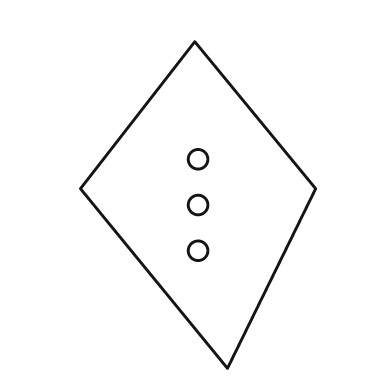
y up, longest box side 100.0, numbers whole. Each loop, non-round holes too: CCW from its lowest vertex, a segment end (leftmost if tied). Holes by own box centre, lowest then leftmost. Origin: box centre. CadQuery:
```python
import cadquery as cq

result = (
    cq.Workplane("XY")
    .moveTo(9.0, -50.0)
    .lineTo(36.0, 5.0)
    .lineTo(-1.0, 50.0)
    .lineTo(-36.0, 5.0)
    .close()
    .moveTo(0.0, -14.0)
    .circle(3.0)
    .moveTo(0.0, 0.0)
    .circle(3.0)
    .moveTo(0.0, 14.0)
    .circle(3.0)
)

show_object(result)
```